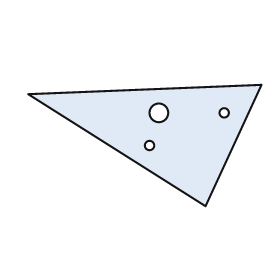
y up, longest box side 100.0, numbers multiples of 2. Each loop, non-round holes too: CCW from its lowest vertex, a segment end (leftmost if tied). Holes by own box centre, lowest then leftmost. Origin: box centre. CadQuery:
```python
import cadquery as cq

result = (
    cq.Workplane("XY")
    .moveTo(26.0, -26.0)
    .lineTo(50.0, 26.0)
    .lineTo(-50.0, 22.0)
    .close()
    .moveTo(2.0, 0.0)
    .circle(2.0)
    .moveTo(6.0, 14.0)
    .circle(4.0)
    .moveTo(34.0, 14.0)
    .circle(2.0)
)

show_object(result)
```